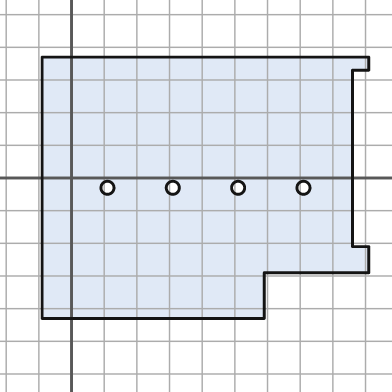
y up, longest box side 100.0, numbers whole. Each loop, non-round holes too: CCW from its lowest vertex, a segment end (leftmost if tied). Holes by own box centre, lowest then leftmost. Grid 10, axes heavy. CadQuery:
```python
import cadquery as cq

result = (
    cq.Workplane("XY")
    .moveTo(-9.0, -43.0)
    .lineTo(59.0, -43.0)
    .lineTo(59.0, -29.0)
    .lineTo(91.0, -29.0)
    .lineTo(91.0, -21.0)
    .lineTo(86.0, -21.0)
    .lineTo(86.0, 33.0)
    .lineTo(91.0, 33.0)
    .lineTo(91.0, 37.0)
    .lineTo(-9.0, 37.0)
    .close()
    .moveTo(11.0, -3.0)
    .circle(2.0)
    .moveTo(31.0, -3.0)
    .circle(2.0)
    .moveTo(51.0, -3.0)
    .circle(2.0)
    .moveTo(71.0, -3.0)
    .circle(2.0)
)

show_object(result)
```